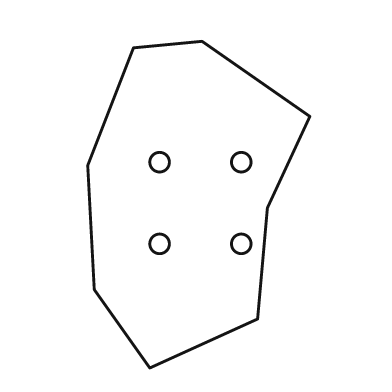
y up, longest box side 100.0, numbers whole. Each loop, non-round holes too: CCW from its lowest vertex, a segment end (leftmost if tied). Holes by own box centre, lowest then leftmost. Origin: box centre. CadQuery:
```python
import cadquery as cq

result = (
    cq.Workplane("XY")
    .moveTo(-15.0, -50.0)
    .lineTo(18.0, -35.0)
    .lineTo(21.0, -1.0)
    .lineTo(34.0, 27.0)
    .lineTo(1.0, 50.0)
    .lineTo(-20.0, 48.0)
    .lineTo(-34.0, 12.0)
    .lineTo(-32.0, -26.0)
    .close()
    .moveTo(-12.0, -12.0)
    .circle(3.0)
    .moveTo(13.0, -12.0)
    .circle(3.0)
    .moveTo(-12.0, 13.0)
    .circle(3.0)
    .moveTo(13.0, 13.0)
    .circle(3.0)
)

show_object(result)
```